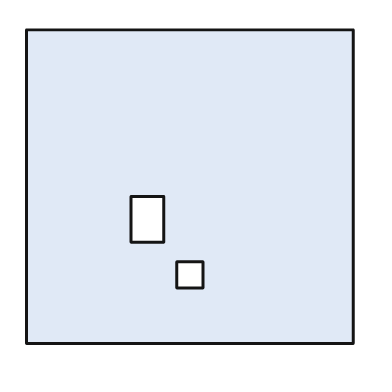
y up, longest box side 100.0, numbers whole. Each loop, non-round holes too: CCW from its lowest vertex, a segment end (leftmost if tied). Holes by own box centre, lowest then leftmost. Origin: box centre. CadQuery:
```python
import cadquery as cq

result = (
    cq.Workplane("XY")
    .moveTo(-50.0, -48.0)
    .lineTo(50.0, -48.0)
    .lineTo(50.0, 48.0)
    .lineTo(-50.0, 48.0)
    .close()
    .moveTo(-4.0, -31.0)
    .lineTo(4.0, -31.0)
    .lineTo(4.0, -23.0)
    .lineTo(-4.0, -23.0)
    .close()
    .moveTo(-18.0, -17.0)
    .lineTo(-8.0, -17.0)
    .lineTo(-8.0, -3.0)
    .lineTo(-18.0, -3.0)
    .close()
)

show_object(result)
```